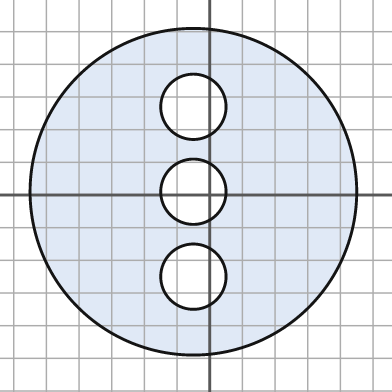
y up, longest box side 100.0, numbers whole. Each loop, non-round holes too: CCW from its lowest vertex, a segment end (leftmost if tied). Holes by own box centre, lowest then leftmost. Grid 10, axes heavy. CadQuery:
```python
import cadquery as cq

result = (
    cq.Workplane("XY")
    .moveTo(-5.0, 1.0)
    .circle(50.0)
    .moveTo(-5.0, -25.0)
    .circle(10.0)
    .moveTo(-5.0, 1.0)
    .circle(10.0)
    .moveTo(-5.0, 27.0)
    .circle(10.0)
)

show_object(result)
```